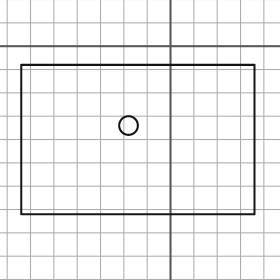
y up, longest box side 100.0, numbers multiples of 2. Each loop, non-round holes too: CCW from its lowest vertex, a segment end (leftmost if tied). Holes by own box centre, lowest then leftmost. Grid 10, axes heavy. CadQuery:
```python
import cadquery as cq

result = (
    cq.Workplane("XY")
    .moveTo(-64.0, -72.0)
    .lineTo(36.0, -72.0)
    .lineTo(36.0, -8.0)
    .lineTo(-64.0, -8.0)
    .close()
    .moveTo(-18.0, -34.0)
    .circle(4.0)
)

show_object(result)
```